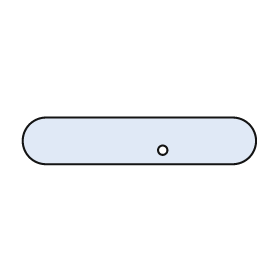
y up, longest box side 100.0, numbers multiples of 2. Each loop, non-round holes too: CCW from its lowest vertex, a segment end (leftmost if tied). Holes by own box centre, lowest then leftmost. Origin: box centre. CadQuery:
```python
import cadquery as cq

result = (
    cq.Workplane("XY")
    .moveTo(-40.0, -10.0)
    .lineTo(40.0, -10.0)
    .threePointArc((50.0, 0.0), (40.0, 10.0))
    .lineTo(-40.0, 10.0)
    .threePointArc((-50.0, 0.0), (-40.0, -10.0))
    .close()
    .moveTo(10.0, -4.0)
    .circle(2.0)
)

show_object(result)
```